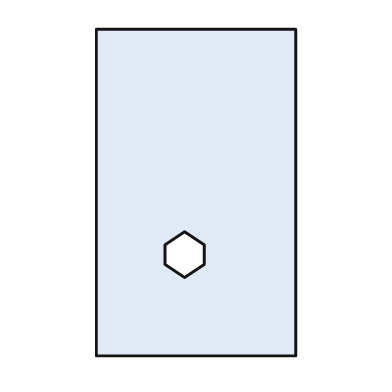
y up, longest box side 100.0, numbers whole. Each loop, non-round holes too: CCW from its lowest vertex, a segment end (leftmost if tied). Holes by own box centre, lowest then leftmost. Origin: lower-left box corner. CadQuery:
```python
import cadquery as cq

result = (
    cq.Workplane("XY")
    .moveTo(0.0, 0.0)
    .lineTo(61.0, 0.0)
    .lineTo(61.0, 100.0)
    .lineTo(0.0, 100.0)
    .close()
    .moveTo(27.0, 24.0)
    .lineTo(33.0, 28.0)
    .lineTo(33.0, 34.0)
    .lineTo(27.0, 38.0)
    .lineTo(21.0, 34.0)
    .lineTo(21.0, 28.0)
    .close()
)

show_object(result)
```